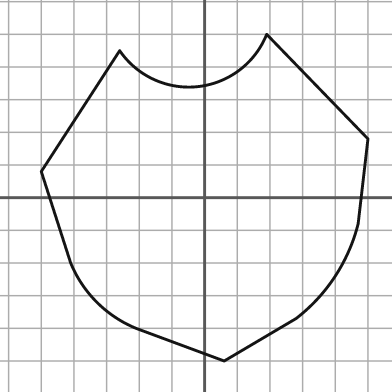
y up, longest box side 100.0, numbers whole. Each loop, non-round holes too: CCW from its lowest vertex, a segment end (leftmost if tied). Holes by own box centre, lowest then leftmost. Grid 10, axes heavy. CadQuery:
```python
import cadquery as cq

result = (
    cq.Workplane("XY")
    .moveTo(6.0, -50.0)
    .lineTo(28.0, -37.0)
    .threePointArc((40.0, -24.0), (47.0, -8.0))
    .lineTo(50.0, 18.0)
    .lineTo(19.0, 50.0)
    .threePointArc((-2.0, 34.0), (-26.0, 45.0))
    .lineTo(-50.0, 8.0)
    .lineTo(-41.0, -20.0)
    .threePointArc((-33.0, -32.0), (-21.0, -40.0))
    .close()
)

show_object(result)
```